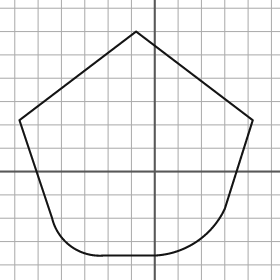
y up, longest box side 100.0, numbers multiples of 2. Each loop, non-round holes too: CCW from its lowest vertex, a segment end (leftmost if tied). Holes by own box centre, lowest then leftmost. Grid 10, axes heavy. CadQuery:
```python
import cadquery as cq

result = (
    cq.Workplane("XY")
    .moveTo(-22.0, -36.0)
    .lineTo(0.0, -36.0)
    .threePointArc((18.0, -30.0), (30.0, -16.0))
    .lineTo(42.0, 22.0)
    .lineTo(-8.0, 60.0)
    .lineTo(-58.0, 22.0)
    .lineTo(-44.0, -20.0)
    .threePointArc((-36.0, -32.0), (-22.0, -36.0))
    .close()
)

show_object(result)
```